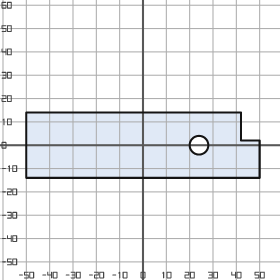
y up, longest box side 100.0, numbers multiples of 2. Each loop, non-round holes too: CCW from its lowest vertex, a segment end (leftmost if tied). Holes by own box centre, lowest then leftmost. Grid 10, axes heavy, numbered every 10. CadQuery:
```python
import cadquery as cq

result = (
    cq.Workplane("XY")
    .moveTo(-50.0, -14.0)
    .lineTo(50.0, -14.0)
    .lineTo(50.0, 2.0)
    .lineTo(42.0, 2.0)
    .lineTo(42.0, 14.0)
    .lineTo(-50.0, 14.0)
    .close()
    .moveTo(24.0, 0.0)
    .circle(4.0)
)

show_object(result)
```